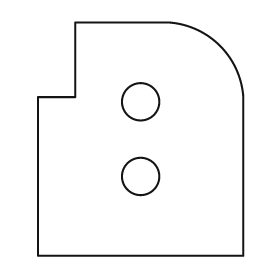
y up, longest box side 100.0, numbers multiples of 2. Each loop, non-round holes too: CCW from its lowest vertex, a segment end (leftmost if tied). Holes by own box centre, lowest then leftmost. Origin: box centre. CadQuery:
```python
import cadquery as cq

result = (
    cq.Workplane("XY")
    .moveTo(-44.0, -50.0)
    .lineTo(44.0, -50.0)
    .lineTo(44.0, 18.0)
    .threePointArc((34.0, 40.0), (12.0, 50.0))
    .lineTo(-28.0, 50.0)
    .lineTo(-28.0, 18.0)
    .lineTo(-44.0, 18.0)
    .close()
    .moveTo(0.0, -16.0)
    .circle(8.0)
    .moveTo(0.0, 16.0)
    .circle(8.0)
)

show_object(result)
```